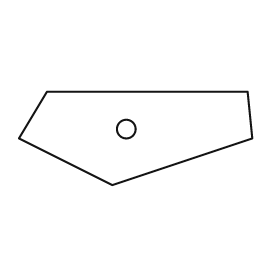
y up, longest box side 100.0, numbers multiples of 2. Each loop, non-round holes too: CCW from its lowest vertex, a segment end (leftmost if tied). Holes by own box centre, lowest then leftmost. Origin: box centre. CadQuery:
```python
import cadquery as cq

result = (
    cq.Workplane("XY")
    .moveTo(-10.0, -20.0)
    .lineTo(50.0, 0.0)
    .lineTo(48.0, 20.0)
    .lineTo(-38.0, 20.0)
    .lineTo(-50.0, 0.0)
    .close()
    .moveTo(-4.0, 4.0)
    .circle(4.0)
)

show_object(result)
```